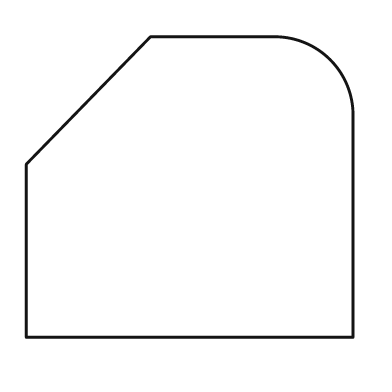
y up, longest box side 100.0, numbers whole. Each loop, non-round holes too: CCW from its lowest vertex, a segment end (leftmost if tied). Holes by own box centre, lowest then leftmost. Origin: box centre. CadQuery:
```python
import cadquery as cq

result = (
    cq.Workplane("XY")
    .moveTo(-50.0, -46.0)
    .lineTo(50.0, -46.0)
    .lineTo(50.0, 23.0)
    .threePointArc((43.0, 39.0), (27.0, 46.0))
    .lineTo(-12.0, 46.0)
    .lineTo(-50.0, 7.0)
    .close()
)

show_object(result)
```